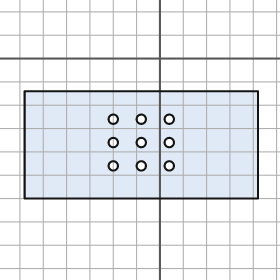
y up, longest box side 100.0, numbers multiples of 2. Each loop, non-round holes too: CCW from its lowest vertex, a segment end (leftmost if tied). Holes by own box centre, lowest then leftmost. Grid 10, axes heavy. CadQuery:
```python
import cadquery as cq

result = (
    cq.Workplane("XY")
    .moveTo(-58.0, -60.0)
    .lineTo(42.0, -60.0)
    .lineTo(42.0, -14.0)
    .lineTo(-58.0, -14.0)
    .close()
    .moveTo(-20.0, -46.0)
    .circle(2.0)
    .moveTo(-8.0, -46.0)
    .circle(2.0)
    .moveTo(4.0, -46.0)
    .circle(2.0)
    .moveTo(-20.0, -36.0)
    .circle(2.0)
    .moveTo(-8.0, -36.0)
    .circle(2.0)
    .moveTo(4.0, -36.0)
    .circle(2.0)
    .moveTo(-20.0, -26.0)
    .circle(2.0)
    .moveTo(-8.0, -26.0)
    .circle(2.0)
    .moveTo(4.0, -26.0)
    .circle(2.0)
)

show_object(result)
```